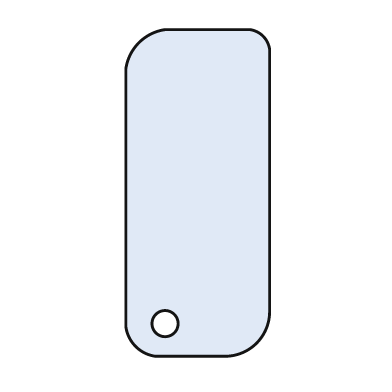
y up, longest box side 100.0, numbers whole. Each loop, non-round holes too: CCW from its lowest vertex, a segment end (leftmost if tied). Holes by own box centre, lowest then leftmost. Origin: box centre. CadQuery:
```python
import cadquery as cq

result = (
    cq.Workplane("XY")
    .moveTo(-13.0, -50.0)
    .lineTo(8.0, -50.0)
    .threePointArc((18.0, -46.0), (22.0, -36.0))
    .lineTo(22.0, 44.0)
    .threePointArc((20.0, 48.0), (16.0, 50.0))
    .lineTo(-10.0, 50.0)
    .threePointArc((-18.0, 46.0), (-22.0, 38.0))
    .lineTo(-22.0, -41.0)
    .threePointArc((-19.0, -47.0), (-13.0, -50.0))
    .close()
    .moveTo(-10.0, -40.0)
    .circle(4.0)
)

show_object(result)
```